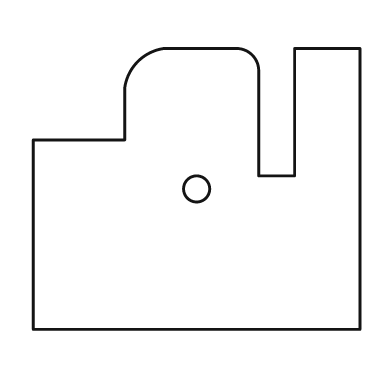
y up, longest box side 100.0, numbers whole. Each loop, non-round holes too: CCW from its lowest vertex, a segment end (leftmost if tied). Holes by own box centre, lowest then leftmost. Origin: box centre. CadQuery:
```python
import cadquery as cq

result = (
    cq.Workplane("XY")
    .moveTo(-50.0, -43.0)
    .lineTo(50.0, -43.0)
    .lineTo(50.0, 43.0)
    .lineTo(30.0, 43.0)
    .lineTo(30.0, 4.0)
    .lineTo(19.0, 4.0)
    .lineTo(19.0, 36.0)
    .threePointArc((17.0, 41.0), (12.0, 43.0))
    .lineTo(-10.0, 43.0)
    .threePointArc((-18.0, 39.0), (-22.0, 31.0))
    .lineTo(-22.0, 15.0)
    .lineTo(-50.0, 15.0)
    .close()
    .moveTo(0.0, 0.0)
    .circle(4.0)
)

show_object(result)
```